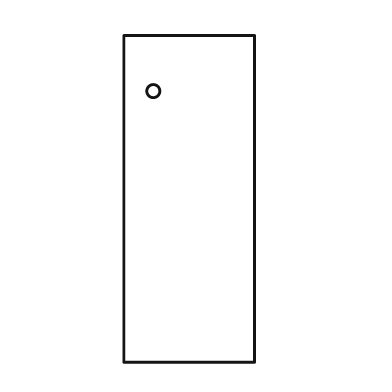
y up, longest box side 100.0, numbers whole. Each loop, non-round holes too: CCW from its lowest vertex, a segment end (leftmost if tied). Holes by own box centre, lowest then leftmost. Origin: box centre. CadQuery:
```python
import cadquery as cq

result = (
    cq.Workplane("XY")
    .moveTo(-20.0, -50.0)
    .lineTo(20.0, -50.0)
    .lineTo(20.0, 50.0)
    .lineTo(-20.0, 50.0)
    .close()
    .moveTo(-11.0, 33.0)
    .circle(2.0)
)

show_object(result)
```